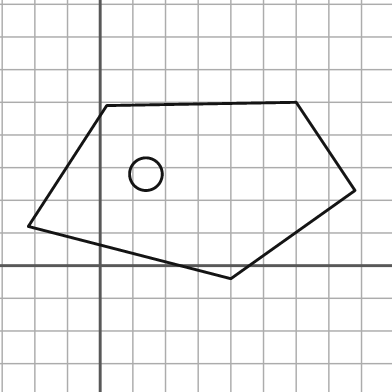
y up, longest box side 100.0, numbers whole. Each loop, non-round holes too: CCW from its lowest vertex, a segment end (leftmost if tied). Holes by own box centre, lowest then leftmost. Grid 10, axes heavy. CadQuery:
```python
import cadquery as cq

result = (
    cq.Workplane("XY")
    .moveTo(40.0, -4.0)
    .lineTo(78.0, 23.0)
    .lineTo(60.0, 50.0)
    .lineTo(2.0, 49.0)
    .lineTo(-22.0, 12.0)
    .close()
    .moveTo(14.0, 28.0)
    .circle(5.0)
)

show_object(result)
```